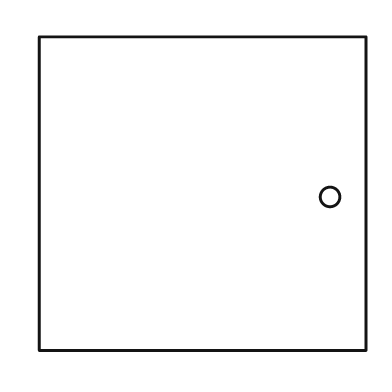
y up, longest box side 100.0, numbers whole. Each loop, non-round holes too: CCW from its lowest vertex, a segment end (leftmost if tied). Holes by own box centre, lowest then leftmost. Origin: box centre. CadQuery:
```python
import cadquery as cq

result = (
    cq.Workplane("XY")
    .moveTo(-50.0, -48.0)
    .lineTo(50.0, -48.0)
    .lineTo(50.0, 48.0)
    .lineTo(-50.0, 48.0)
    .close()
    .moveTo(39.0, -1.0)
    .circle(3.0)
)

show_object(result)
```